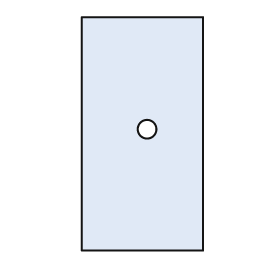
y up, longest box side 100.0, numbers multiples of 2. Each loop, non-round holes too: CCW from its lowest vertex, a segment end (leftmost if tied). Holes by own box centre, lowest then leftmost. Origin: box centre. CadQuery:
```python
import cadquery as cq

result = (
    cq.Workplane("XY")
    .moveTo(-26.0, -50.0)
    .lineTo(26.0, -50.0)
    .lineTo(26.0, 50.0)
    .lineTo(-26.0, 50.0)
    .close()
    .moveTo(2.0, 2.0)
    .circle(4.0)
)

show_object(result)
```